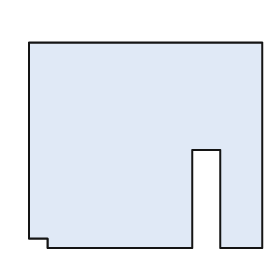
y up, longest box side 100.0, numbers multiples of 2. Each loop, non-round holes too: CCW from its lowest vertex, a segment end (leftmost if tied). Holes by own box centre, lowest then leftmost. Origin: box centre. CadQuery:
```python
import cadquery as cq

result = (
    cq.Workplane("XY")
    .moveTo(-42.0, -44.0)
    .lineTo(20.0, -44.0)
    .lineTo(20.0, -2.0)
    .lineTo(32.0, -2.0)
    .lineTo(32.0, -44.0)
    .lineTo(50.0, -44.0)
    .lineTo(50.0, 44.0)
    .lineTo(-50.0, 44.0)
    .lineTo(-50.0, -40.0)
    .lineTo(-42.0, -40.0)
    .close()
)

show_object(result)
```